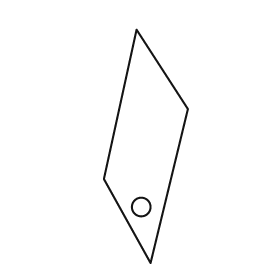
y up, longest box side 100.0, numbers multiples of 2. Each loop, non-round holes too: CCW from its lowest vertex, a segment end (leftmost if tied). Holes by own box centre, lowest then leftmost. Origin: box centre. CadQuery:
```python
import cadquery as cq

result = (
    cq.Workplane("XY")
    .moveTo(2.0, -50.0)
    .lineTo(18.0, 16.0)
    .lineTo(-4.0, 50.0)
    .lineTo(-18.0, -14.0)
    .close()
    .moveTo(-2.0, -26.0)
    .circle(4.0)
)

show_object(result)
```